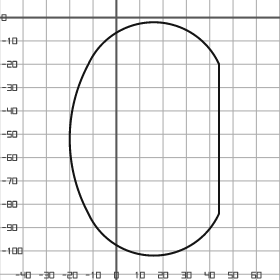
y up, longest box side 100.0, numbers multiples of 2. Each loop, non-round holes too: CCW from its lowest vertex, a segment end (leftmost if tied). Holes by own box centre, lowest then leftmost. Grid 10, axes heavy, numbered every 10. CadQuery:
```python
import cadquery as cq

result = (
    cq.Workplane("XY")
    .moveTo(-12.0, -84.0)
    .threePointArc((16.0, -102.0), (44.0, -84.0))
    .lineTo(44.0, -20.0)
    .threePointArc((16.0, -2.0), (-12.0, -20.0))
    .threePointArc((-20.0, -52.0), (-12.0, -84.0))
    .close()
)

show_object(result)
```